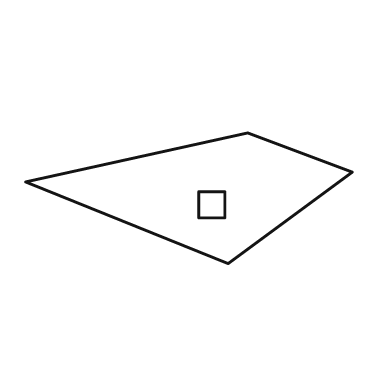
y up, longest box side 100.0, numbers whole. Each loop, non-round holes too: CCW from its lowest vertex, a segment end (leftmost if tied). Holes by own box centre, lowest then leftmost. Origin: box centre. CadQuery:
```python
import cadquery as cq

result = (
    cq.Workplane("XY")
    .moveTo(12.0, -20.0)
    .lineTo(50.0, 8.0)
    .lineTo(18.0, 20.0)
    .lineTo(-50.0, 5.0)
    .close()
    .moveTo(3.0, -6.0)
    .lineTo(11.0, -6.0)
    .lineTo(11.0, 2.0)
    .lineTo(3.0, 2.0)
    .close()
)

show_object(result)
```